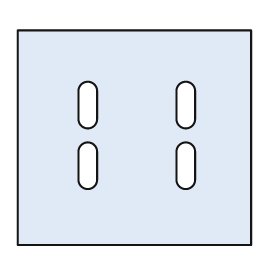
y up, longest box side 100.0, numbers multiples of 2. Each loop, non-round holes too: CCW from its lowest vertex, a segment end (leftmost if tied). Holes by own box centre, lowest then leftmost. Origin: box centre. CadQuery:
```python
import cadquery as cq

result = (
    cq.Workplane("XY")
    .moveTo(-50.0, -46.0)
    .lineTo(50.0, -46.0)
    .lineTo(50.0, 46.0)
    .lineTo(-50.0, 46.0)
    .close()
    .moveTo(-24.0, -18.0)
    .threePointArc((-20.0, -22.0), (-16.0, -18.0))
    .lineTo(-16.0, -6.0)
    .threePointArc((-20.0, -2.0), (-24.0, -6.0))
    .close()
    .moveTo(18.0, -18.0)
    .threePointArc((22.0, -22.0), (26.0, -18.0))
    .lineTo(26.0, -6.0)
    .threePointArc((22.0, -2.0), (18.0, -6.0))
    .close()
    .moveTo(-24.0, 8.0)
    .threePointArc((-20.0, 4.0), (-16.0, 8.0))
    .lineTo(-16.0, 20.0)
    .threePointArc((-20.0, 24.0), (-24.0, 20.0))
    .close()
    .moveTo(18.0, 8.0)
    .threePointArc((22.0, 4.0), (26.0, 8.0))
    .lineTo(26.0, 20.0)
    .threePointArc((22.0, 24.0), (18.0, 20.0))
    .close()
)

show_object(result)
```